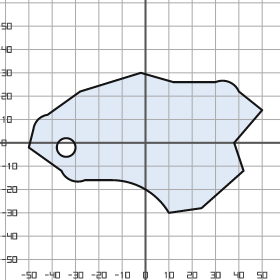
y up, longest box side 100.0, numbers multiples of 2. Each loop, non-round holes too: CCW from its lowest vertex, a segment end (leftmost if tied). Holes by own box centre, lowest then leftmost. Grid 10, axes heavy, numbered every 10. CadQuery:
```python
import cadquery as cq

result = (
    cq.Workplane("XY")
    .moveTo(10.0, -30.0)
    .lineTo(24.0, -28.0)
    .lineTo(42.0, -12.0)
    .lineTo(38.0, 0.0)
    .lineTo(50.0, 14.0)
    .lineTo(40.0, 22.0)
    .threePointArc((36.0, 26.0), (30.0, 26.0))
    .lineTo(12.0, 26.0)
    .lineTo(-2.0, 30.0)
    .lineTo(-28.0, 22.0)
    .lineTo(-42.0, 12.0)
    .threePointArc((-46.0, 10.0), (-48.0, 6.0))
    .lineTo(-50.0, -2.0)
    .lineTo(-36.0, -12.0)
    .threePointArc((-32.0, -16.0), (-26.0, -16.0))
    .lineTo(-14.0, -16.0)
    .threePointArc((0.0, -20.0), (10.0, -30.0))
    .close()
    .moveTo(-34.0, -2.0)
    .circle(4.0)
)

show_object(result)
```